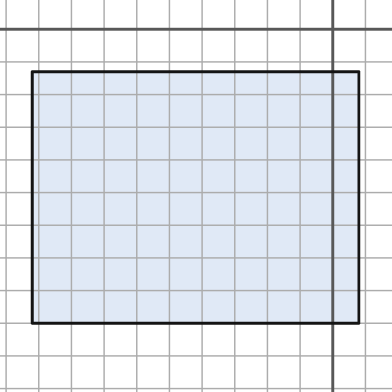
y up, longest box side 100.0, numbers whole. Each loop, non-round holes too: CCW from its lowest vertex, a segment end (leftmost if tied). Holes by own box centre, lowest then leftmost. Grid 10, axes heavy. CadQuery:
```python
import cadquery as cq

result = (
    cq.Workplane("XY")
    .moveTo(-92.0, -90.0)
    .lineTo(8.0, -90.0)
    .lineTo(8.0, -13.0)
    .lineTo(-92.0, -13.0)
    .close()
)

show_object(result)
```